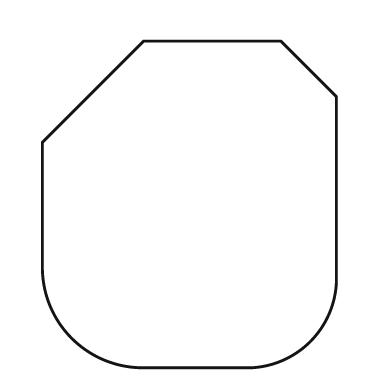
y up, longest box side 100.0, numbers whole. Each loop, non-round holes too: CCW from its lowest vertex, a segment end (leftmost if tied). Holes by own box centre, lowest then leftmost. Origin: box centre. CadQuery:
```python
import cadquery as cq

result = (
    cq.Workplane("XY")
    .moveTo(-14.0, -50.0)
    .lineTo(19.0, -50.0)
    .threePointArc((37.0, -42.0), (45.0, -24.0))
    .lineTo(45.0, 33.0)
    .lineTo(28.0, 50.0)
    .lineTo(-14.0, 50.0)
    .lineTo(-45.0, 19.0)
    .lineTo(-45.0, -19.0)
    .threePointArc((-36.0, -41.0), (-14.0, -50.0))
    .close()
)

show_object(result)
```